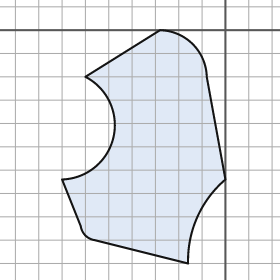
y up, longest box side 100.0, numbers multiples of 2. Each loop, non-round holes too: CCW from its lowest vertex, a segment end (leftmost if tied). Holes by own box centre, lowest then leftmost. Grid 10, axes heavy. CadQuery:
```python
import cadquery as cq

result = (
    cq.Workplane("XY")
    .moveTo(-16.0, -100.0)
    .threePointArc((-12.0, -80.0), (0.0, -64.0))
    .lineTo(-8.0, -20.0)
    .threePointArc((-14.0, -6.0), (-28.0, 0.0))
    .lineTo(-60.0, -20.0)
    .threePointArc((-48.0, -46.0), (-70.0, -64.0))
    .lineTo(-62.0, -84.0)
    .threePointArc((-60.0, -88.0), (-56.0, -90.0))
    .close()
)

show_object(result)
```